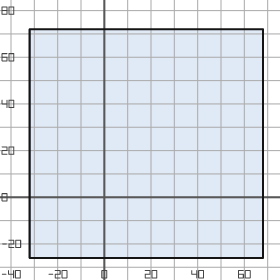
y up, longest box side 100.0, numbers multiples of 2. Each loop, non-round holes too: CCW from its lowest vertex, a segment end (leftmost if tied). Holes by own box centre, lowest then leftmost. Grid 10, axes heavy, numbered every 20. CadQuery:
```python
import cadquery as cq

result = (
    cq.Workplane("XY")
    .moveTo(-32.0, -26.0)
    .lineTo(68.0, -26.0)
    .lineTo(68.0, 72.0)
    .lineTo(-32.0, 72.0)
    .close()
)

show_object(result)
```